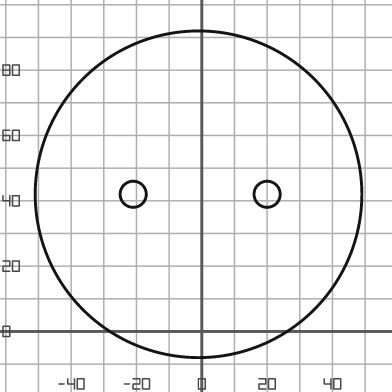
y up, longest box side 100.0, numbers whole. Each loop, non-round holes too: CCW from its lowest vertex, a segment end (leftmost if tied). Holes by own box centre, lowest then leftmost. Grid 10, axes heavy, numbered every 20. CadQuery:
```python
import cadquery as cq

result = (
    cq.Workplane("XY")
    .moveTo(-1.0, 42.0)
    .circle(50.0)
    .moveTo(-21.0, 42.0)
    .circle(4.0)
    .moveTo(20.0, 42.0)
    .circle(4.0)
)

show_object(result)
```